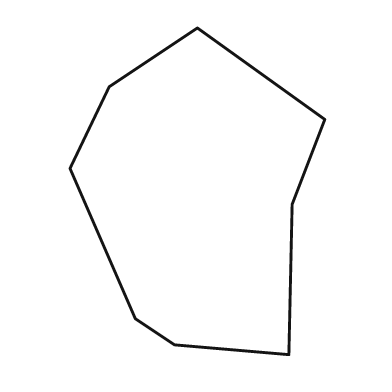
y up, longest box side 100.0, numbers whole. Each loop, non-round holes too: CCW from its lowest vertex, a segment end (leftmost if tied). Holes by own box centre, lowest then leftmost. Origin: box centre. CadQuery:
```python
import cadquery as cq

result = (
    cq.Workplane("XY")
    .moveTo(28.0, -50.0)
    .lineTo(29.0, -4.0)
    .lineTo(39.0, 22.0)
    .lineTo(0.0, 50.0)
    .lineTo(-27.0, 32.0)
    .lineTo(-39.0, 7.0)
    .lineTo(-19.0, -39.0)
    .lineTo(-7.0, -47.0)
    .close()
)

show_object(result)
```